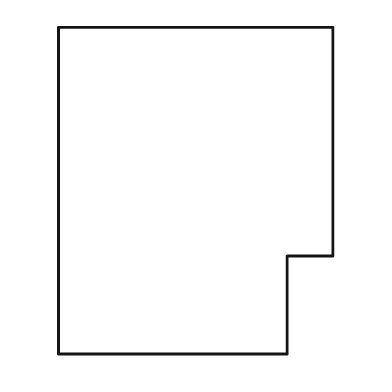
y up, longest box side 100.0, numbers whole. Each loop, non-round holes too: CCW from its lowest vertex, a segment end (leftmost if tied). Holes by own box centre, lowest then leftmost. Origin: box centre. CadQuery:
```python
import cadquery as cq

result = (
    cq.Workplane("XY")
    .moveTo(-42.0, -50.0)
    .lineTo(28.0, -50.0)
    .lineTo(28.0, -20.0)
    .lineTo(42.0, -20.0)
    .lineTo(42.0, 50.0)
    .lineTo(-42.0, 50.0)
    .close()
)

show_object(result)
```